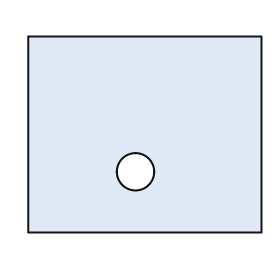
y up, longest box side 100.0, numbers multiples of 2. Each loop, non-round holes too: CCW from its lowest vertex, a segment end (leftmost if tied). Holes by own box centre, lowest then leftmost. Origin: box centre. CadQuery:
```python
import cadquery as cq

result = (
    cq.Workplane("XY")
    .moveTo(-50.0, -42.0)
    .lineTo(50.0, -42.0)
    .lineTo(50.0, 42.0)
    .lineTo(-50.0, 42.0)
    .close()
    .moveTo(-4.0, -16.0)
    .circle(8.0)
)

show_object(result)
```